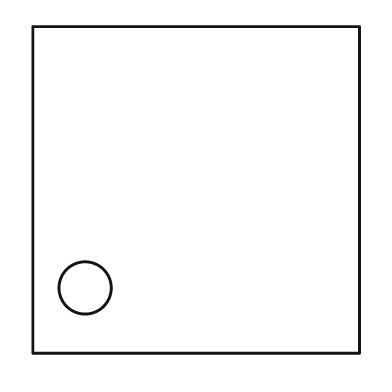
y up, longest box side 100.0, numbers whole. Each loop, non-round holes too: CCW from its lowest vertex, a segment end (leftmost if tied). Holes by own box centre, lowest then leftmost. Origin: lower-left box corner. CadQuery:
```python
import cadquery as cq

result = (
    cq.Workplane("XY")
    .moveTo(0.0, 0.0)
    .lineTo(100.0, 0.0)
    .lineTo(100.0, 100.0)
    .lineTo(0.0, 100.0)
    .close()
    .moveTo(16.0, 20.0)
    .circle(8.0)
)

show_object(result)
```